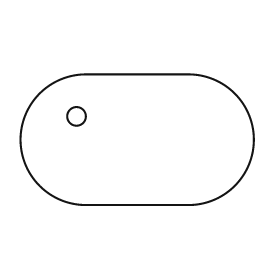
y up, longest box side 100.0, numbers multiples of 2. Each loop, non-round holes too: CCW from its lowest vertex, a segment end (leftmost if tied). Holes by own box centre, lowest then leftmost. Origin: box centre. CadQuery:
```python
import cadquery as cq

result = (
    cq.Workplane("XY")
    .moveTo(-22.0, -28.0)
    .lineTo(22.0, -28.0)
    .threePointArc((50.0, 0.0), (22.0, 28.0))
    .lineTo(-22.0, 28.0)
    .threePointArc((-50.0, 0.0), (-22.0, -28.0))
    .close()
    .moveTo(-26.0, 10.0)
    .circle(4.0)
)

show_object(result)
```